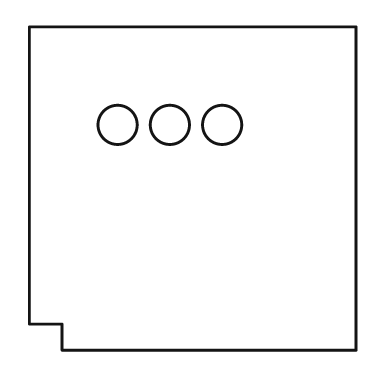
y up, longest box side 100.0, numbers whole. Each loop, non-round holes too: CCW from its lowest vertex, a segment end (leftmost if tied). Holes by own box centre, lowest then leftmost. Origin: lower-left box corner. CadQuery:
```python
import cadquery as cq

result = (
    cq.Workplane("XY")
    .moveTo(10.0, 0.0)
    .lineTo(100.0, 0.0)
    .lineTo(100.0, 99.0)
    .lineTo(0.0, 99.0)
    .lineTo(0.0, 8.0)
    .lineTo(10.0, 8.0)
    .close()
    .moveTo(27.0, 69.0)
    .circle(6.0)
    .moveTo(43.0, 69.0)
    .circle(6.0)
    .moveTo(59.0, 69.0)
    .circle(6.0)
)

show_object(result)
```